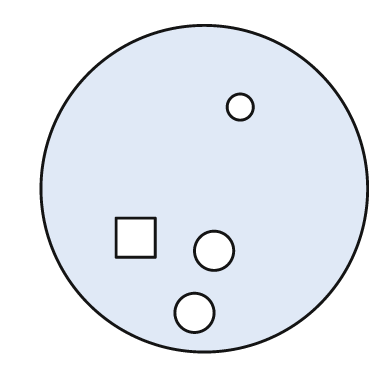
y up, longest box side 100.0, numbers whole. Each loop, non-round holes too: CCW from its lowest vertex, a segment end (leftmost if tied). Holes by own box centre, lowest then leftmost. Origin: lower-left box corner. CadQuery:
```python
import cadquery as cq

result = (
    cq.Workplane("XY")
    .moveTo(50.0, 50.0)
    .circle(50.0)
    .moveTo(47.0, 12.0)
    .circle(6.0)
    .moveTo(53.0, 31.0)
    .circle(6.0)
    .moveTo(23.0, 29.0)
    .lineTo(35.0, 29.0)
    .lineTo(35.0, 41.0)
    .lineTo(23.0, 41.0)
    .close()
    .moveTo(61.0, 75.0)
    .circle(4.0)
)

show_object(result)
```